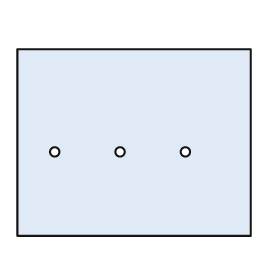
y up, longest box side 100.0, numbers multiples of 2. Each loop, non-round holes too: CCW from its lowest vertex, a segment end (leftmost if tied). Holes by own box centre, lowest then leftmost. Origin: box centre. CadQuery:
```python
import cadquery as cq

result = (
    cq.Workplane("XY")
    .moveTo(-50.0, -40.0)
    .lineTo(50.0, -40.0)
    .lineTo(50.0, 40.0)
    .lineTo(-50.0, 40.0)
    .close()
    .moveTo(-34.0, -4.0)
    .circle(2.0)
    .moveTo(-6.0, -4.0)
    .circle(2.0)
    .moveTo(22.0, -4.0)
    .circle(2.0)
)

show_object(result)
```